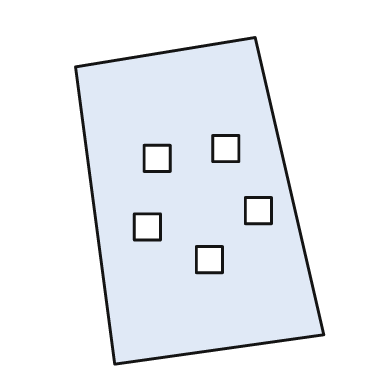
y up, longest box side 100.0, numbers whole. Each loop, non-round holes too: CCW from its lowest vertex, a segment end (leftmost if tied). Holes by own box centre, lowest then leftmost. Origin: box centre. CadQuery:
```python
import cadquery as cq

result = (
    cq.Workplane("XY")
    .moveTo(-26.0, -50.0)
    .lineTo(38.0, -41.0)
    .lineTo(17.0, 50.0)
    .lineTo(-38.0, 41.0)
    .close()
    .moveTo(-1.0, -22.0)
    .lineTo(7.0, -22.0)
    .lineTo(7.0, -14.0)
    .lineTo(-1.0, -14.0)
    .close()
    .moveTo(-20.0, -12.0)
    .lineTo(-12.0, -12.0)
    .lineTo(-12.0, -4.0)
    .lineTo(-20.0, -4.0)
    .close()
    .moveTo(14.0, -7.0)
    .lineTo(22.0, -7.0)
    .lineTo(22.0, 1.0)
    .lineTo(14.0, 1.0)
    .close()
    .moveTo(-17.0, 9.0)
    .lineTo(-9.0, 9.0)
    .lineTo(-9.0, 17.0)
    .lineTo(-17.0, 17.0)
    .close()
    .moveTo(4.0, 12.0)
    .lineTo(12.0, 12.0)
    .lineTo(12.0, 20.0)
    .lineTo(4.0, 20.0)
    .close()
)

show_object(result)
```